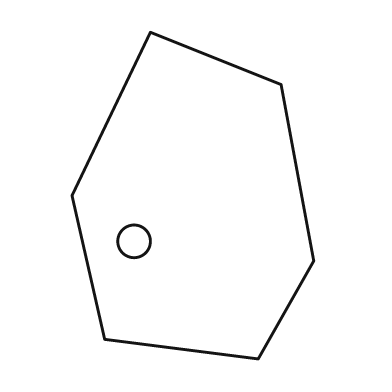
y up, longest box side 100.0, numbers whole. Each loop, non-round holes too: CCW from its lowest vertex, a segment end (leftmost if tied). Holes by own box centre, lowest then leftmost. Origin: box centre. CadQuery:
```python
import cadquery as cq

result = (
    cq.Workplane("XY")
    .moveTo(20.0, -50.0)
    .lineTo(37.0, -20.0)
    .lineTo(27.0, 34.0)
    .lineTo(-13.0, 50.0)
    .lineTo(-37.0, 0.0)
    .lineTo(-27.0, -44.0)
    .close()
    .moveTo(-18.0, -14.0)
    .circle(5.0)
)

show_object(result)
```